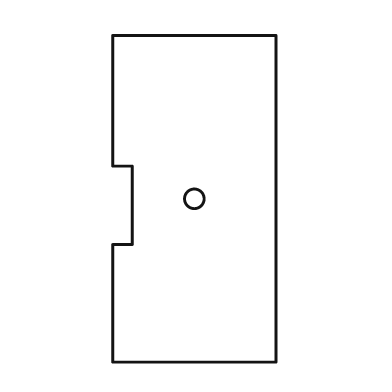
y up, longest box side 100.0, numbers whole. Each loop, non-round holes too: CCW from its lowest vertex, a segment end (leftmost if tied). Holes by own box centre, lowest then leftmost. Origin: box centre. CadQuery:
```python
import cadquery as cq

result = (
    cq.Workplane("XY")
    .moveTo(-25.0, -50.0)
    .lineTo(25.0, -50.0)
    .lineTo(25.0, 50.0)
    .lineTo(-25.0, 50.0)
    .lineTo(-25.0, 10.0)
    .lineTo(-19.0, 10.0)
    .lineTo(-19.0, -14.0)
    .lineTo(-25.0, -14.0)
    .close()
    .moveTo(0.0, 0.0)
    .circle(3.0)
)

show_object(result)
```